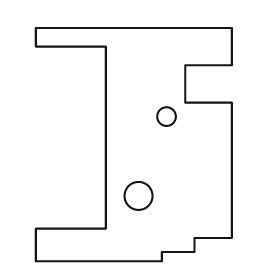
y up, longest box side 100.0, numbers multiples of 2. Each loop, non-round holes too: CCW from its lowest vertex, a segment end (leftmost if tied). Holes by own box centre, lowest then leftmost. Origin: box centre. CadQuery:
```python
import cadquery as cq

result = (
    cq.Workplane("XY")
    .moveTo(-42.0, -50.0)
    .lineTo(12.0, -50.0)
    .lineTo(12.0, -46.0)
    .lineTo(26.0, -46.0)
    .lineTo(26.0, -40.0)
    .lineTo(42.0, -40.0)
    .lineTo(42.0, 18.0)
    .lineTo(22.0, 18.0)
    .lineTo(22.0, 34.0)
    .lineTo(42.0, 34.0)
    .lineTo(42.0, 50.0)
    .lineTo(-42.0, 50.0)
    .lineTo(-42.0, 42.0)
    .lineTo(-12.0, 42.0)
    .lineTo(-12.0, -36.0)
    .lineTo(-42.0, -36.0)
    .close()
    .moveTo(2.0, -22.0)
    .circle(6.0)
    .moveTo(14.0, 12.0)
    .circle(4.0)
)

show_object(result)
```